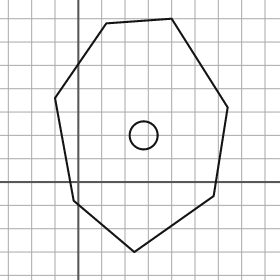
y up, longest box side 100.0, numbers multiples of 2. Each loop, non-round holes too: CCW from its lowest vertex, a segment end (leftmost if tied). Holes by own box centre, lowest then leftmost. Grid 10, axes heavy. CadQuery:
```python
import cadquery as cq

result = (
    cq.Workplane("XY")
    .moveTo(24.0, -30.0)
    .lineTo(58.0, -6.0)
    .lineTo(64.0, 32.0)
    .lineTo(40.0, 70.0)
    .lineTo(12.0, 68.0)
    .lineTo(-10.0, 36.0)
    .lineTo(-2.0, -8.0)
    .close()
    .moveTo(28.0, 20.0)
    .circle(6.0)
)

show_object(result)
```